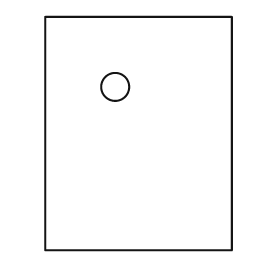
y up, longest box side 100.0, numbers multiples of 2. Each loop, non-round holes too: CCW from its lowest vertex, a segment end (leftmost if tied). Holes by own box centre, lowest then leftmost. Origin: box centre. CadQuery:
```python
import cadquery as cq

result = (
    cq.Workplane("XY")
    .moveTo(-40.0, -50.0)
    .lineTo(40.0, -50.0)
    .lineTo(40.0, 50.0)
    .lineTo(-40.0, 50.0)
    .close()
    .moveTo(-10.0, 20.0)
    .circle(6.0)
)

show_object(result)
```